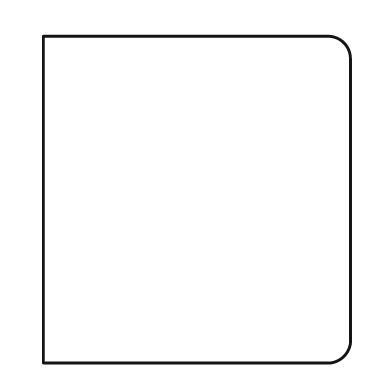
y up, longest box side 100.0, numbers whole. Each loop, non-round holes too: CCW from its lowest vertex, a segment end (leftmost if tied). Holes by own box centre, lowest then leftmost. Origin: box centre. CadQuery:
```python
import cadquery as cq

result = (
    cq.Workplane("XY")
    .moveTo(-47.0, -50.0)
    .lineTo(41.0, -50.0)
    .threePointArc((45.0, -48.0), (47.0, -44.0))
    .lineTo(47.0, 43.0)
    .threePointArc((45.0, 48.0), (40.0, 50.0))
    .lineTo(-47.0, 50.0)
    .close()
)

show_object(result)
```